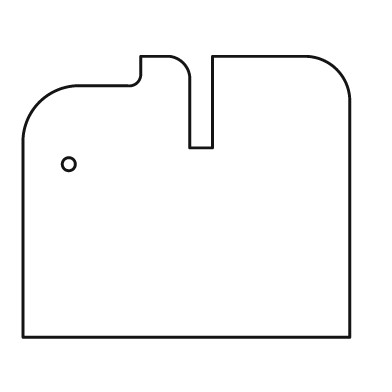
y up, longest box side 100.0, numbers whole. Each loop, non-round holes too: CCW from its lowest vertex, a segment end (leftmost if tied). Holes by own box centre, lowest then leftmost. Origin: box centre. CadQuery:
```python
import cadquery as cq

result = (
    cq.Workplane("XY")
    .moveTo(-50.0, -43.0)
    .lineTo(50.0, -43.0)
    .lineTo(50.0, 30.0)
    .threePointArc((46.0, 39.0), (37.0, 43.0))
    .lineTo(8.0, 43.0)
    .lineTo(8.0, 15.0)
    .lineTo(1.0, 15.0)
    .lineTo(1.0, 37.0)
    .threePointArc((-1.0, 41.0), (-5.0, 43.0))
    .lineTo(-14.0, 43.0)
    .lineTo(-14.0, 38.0)
    .threePointArc((-15.0, 35.0), (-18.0, 34.0))
    .lineTo(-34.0, 34.0)
    .threePointArc((-45.0, 29.0), (-50.0, 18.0))
    .close()
    .moveTo(-36.0, 10.0)
    .circle(2.0)
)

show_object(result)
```